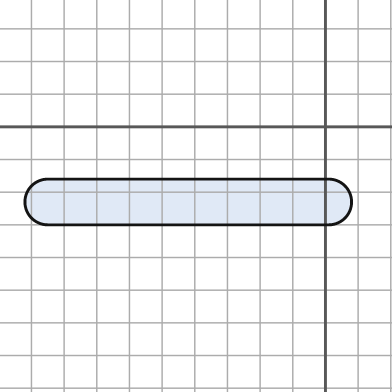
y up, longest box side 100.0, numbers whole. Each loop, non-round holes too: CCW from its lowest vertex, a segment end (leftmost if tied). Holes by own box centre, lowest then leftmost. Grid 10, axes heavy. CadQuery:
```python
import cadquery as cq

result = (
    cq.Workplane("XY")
    .moveTo(-85.0, -30.0)
    .lineTo(1.0, -30.0)
    .threePointArc((8.0, -23.0), (1.0, -16.0))
    .lineTo(-85.0, -16.0)
    .threePointArc((-92.0, -23.0), (-85.0, -30.0))
    .close()
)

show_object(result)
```